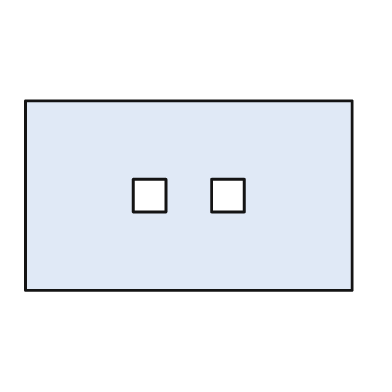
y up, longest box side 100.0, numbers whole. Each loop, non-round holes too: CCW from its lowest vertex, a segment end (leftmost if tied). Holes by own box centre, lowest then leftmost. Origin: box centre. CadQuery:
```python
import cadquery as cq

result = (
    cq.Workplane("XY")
    .moveTo(-50.0, -29.0)
    .lineTo(50.0, -29.0)
    .lineTo(50.0, 29.0)
    .lineTo(-50.0, 29.0)
    .close()
    .moveTo(-17.0, -5.0)
    .lineTo(-7.0, -5.0)
    .lineTo(-7.0, 5.0)
    .lineTo(-17.0, 5.0)
    .close()
    .moveTo(7.0, -5.0)
    .lineTo(17.0, -5.0)
    .lineTo(17.0, 5.0)
    .lineTo(7.0, 5.0)
    .close()
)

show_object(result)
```